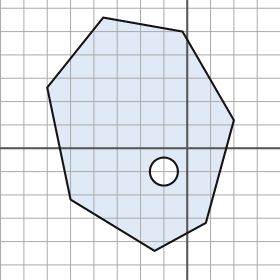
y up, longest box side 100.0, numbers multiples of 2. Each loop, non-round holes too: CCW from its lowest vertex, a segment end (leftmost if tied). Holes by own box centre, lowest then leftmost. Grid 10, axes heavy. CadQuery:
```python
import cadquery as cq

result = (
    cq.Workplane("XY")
    .moveTo(-14.0, -44.0)
    .lineTo(8.0, -32.0)
    .lineTo(20.0, 12.0)
    .lineTo(-2.0, 50.0)
    .lineTo(-36.0, 56.0)
    .lineTo(-60.0, 26.0)
    .lineTo(-50.0, -22.0)
    .close()
    .moveTo(-10.0, -10.0)
    .circle(6.0)
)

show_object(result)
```